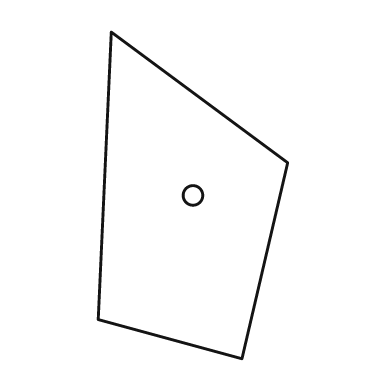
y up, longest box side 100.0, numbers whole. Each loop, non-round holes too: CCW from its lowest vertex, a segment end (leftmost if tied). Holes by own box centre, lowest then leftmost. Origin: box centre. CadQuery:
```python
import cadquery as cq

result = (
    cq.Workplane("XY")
    .moveTo(15.0, -50.0)
    .lineTo(29.0, 10.0)
    .lineTo(-25.0, 50.0)
    .lineTo(-29.0, -38.0)
    .close()
    .moveTo(0.0, 0.0)
    .circle(3.0)
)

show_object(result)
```